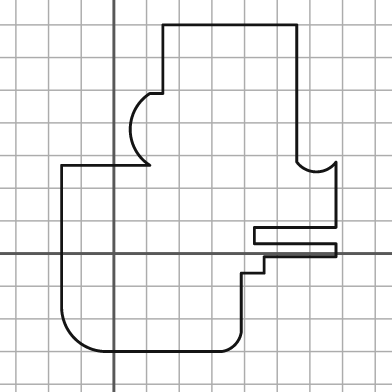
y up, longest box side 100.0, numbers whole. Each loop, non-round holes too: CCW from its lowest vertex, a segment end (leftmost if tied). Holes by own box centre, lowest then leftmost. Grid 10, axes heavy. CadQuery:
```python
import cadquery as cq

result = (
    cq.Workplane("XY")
    .moveTo(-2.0, -30.0)
    .lineTo(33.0, -30.0)
    .threePointArc((37.0, -28.0), (39.0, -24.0))
    .lineTo(39.0, -6.0)
    .lineTo(46.0, -6.0)
    .lineTo(46.0, -1.0)
    .lineTo(68.0, -1.0)
    .lineTo(68.0, 3.0)
    .lineTo(43.0, 3.0)
    .lineTo(43.0, 8.0)
    .lineTo(68.0, 8.0)
    .lineTo(68.0, 28.0)
    .threePointArc((62.0, 25.0), (56.0, 28.0))
    .lineTo(56.0, 70.0)
    .lineTo(15.0, 70.0)
    .lineTo(15.0, 49.0)
    .lineTo(11.0, 49.0)
    .threePointArc((5.0, 38.0), (11.0, 27.0))
    .lineTo(-16.0, 27.0)
    .lineTo(-16.0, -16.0)
    .threePointArc((-12.0, -26.0), (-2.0, -30.0))
    .close()
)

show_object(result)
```